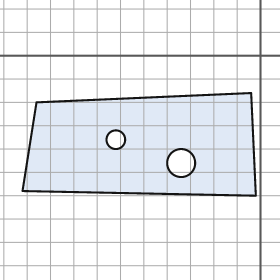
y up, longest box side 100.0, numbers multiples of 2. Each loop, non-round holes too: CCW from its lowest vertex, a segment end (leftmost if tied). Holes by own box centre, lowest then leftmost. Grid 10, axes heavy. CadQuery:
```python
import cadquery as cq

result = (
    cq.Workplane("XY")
    .moveTo(-2.0, -60.0)
    .lineTo(-4.0, -16.0)
    .lineTo(-96.0, -20.0)
    .lineTo(-102.0, -58.0)
    .close()
    .moveTo(-34.0, -46.0)
    .circle(6.0)
    .moveTo(-62.0, -36.0)
    .circle(4.0)
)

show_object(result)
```